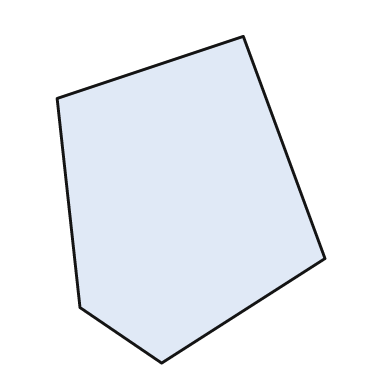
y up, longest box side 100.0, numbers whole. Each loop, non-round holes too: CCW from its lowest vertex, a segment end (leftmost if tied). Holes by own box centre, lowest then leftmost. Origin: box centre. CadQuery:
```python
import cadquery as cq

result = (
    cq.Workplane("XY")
    .moveTo(-9.0, -50.0)
    .lineTo(41.0, -18.0)
    .lineTo(16.0, 50.0)
    .lineTo(-41.0, 31.0)
    .lineTo(-34.0, -33.0)
    .close()
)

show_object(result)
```